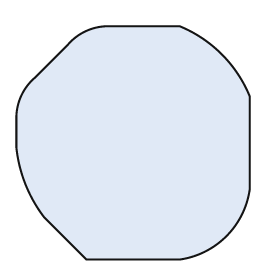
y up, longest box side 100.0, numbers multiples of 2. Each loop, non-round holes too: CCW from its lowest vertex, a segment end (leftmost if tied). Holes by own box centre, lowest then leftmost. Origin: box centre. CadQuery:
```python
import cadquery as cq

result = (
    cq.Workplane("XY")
    .moveTo(-20.0, -50.0)
    .lineTo(20.0, -50.0)
    .threePointArc((40.0, -40.0), (50.0, -20.0))
    .lineTo(50.0, 20.0)
    .threePointArc((38.0, 38.0), (20.0, 50.0))
    .lineTo(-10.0, 50.0)
    .threePointArc((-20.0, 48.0), (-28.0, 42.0))
    .lineTo(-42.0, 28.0)
    .threePointArc((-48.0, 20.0), (-50.0, 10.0))
    .lineTo(-50.0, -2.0)
    .threePointArc((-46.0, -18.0), (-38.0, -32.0))
    .close()
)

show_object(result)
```